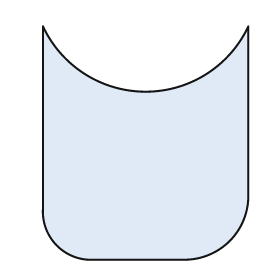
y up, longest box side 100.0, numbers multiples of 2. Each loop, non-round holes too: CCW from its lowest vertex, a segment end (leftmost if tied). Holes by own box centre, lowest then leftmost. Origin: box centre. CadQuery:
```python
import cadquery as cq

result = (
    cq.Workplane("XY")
    .moveTo(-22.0, -50.0)
    .lineTo(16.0, -50.0)
    .threePointArc((36.0, -42.0), (44.0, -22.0))
    .lineTo(44.0, 50.0)
    .threePointArc((0.0, 22.0), (-44.0, 50.0))
    .lineTo(-44.0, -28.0)
    .threePointArc((-38.0, -44.0), (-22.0, -50.0))
    .close()
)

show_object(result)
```